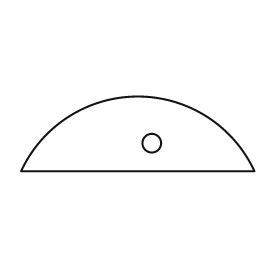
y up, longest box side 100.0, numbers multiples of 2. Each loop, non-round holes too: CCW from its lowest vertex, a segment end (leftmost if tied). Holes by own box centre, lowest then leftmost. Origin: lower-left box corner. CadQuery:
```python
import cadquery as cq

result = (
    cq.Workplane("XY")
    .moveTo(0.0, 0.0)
    .lineTo(100.0, 0.0)
    .threePointArc((50.0, 32.0), (0.0, 0.0))
    .close()
    .moveTo(56.0, 12.0)
    .circle(4.0)
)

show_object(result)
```